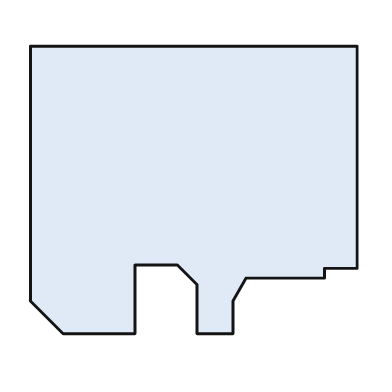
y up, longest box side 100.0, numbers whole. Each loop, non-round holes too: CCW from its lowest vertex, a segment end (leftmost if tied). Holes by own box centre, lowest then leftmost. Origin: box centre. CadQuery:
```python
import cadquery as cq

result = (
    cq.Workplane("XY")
    .moveTo(-40.0, -44.0)
    .lineTo(-18.0, -44.0)
    .lineTo(-18.0, -23.0)
    .lineTo(-5.0, -23.0)
    .lineTo(1.0, -29.0)
    .lineTo(1.0, -44.0)
    .lineTo(12.0, -44.0)
    .lineTo(12.0, -34.0)
    .lineTo(16.0, -27.0)
    .lineTo(40.0, -27.0)
    .lineTo(40.0, -24.0)
    .lineTo(50.0, -24.0)
    .lineTo(50.0, 44.0)
    .lineTo(-50.0, 44.0)
    .lineTo(-50.0, -34.0)
    .close()
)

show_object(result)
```